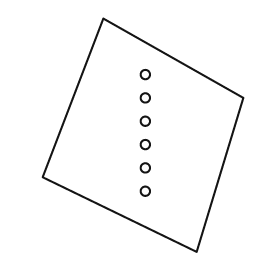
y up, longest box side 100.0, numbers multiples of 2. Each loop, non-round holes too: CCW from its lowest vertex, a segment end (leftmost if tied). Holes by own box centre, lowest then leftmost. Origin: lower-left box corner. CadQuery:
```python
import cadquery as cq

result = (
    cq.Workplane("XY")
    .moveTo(66.0, 0.0)
    .lineTo(86.0, 66.0)
    .lineTo(26.0, 100.0)
    .lineTo(0.0, 32.0)
    .close()
    .moveTo(44.0, 26.0)
    .circle(2.0)
    .moveTo(44.0, 36.0)
    .circle(2.0)
    .moveTo(44.0, 46.0)
    .circle(2.0)
    .moveTo(44.0, 56.0)
    .circle(2.0)
    .moveTo(44.0, 66.0)
    .circle(2.0)
    .moveTo(44.0, 76.0)
    .circle(2.0)
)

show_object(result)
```